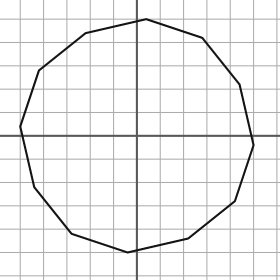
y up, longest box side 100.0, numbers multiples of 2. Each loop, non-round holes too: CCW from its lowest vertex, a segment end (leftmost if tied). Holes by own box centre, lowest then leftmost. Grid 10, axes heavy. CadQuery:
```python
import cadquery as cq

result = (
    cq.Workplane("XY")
    .moveTo(-4.0, -50.0)
    .lineTo(22.0, -44.0)
    .lineTo(42.0, -28.0)
    .lineTo(50.0, -4.0)
    .lineTo(44.0, 22.0)
    .lineTo(28.0, 42.0)
    .lineTo(4.0, 50.0)
    .lineTo(-22.0, 44.0)
    .lineTo(-42.0, 28.0)
    .lineTo(-50.0, 4.0)
    .lineTo(-44.0, -22.0)
    .lineTo(-28.0, -42.0)
    .close()
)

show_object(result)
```